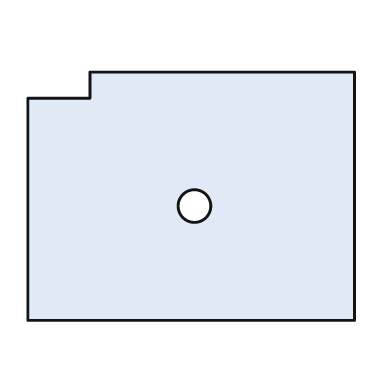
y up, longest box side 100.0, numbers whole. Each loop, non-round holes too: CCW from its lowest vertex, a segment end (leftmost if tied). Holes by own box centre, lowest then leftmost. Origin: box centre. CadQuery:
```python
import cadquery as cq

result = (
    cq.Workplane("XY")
    .moveTo(-50.0, -38.0)
    .lineTo(50.0, -38.0)
    .lineTo(50.0, 38.0)
    .lineTo(-31.0, 38.0)
    .lineTo(-31.0, 30.0)
    .lineTo(-50.0, 30.0)
    .close()
    .moveTo(1.0, -3.0)
    .circle(5.0)
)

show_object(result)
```